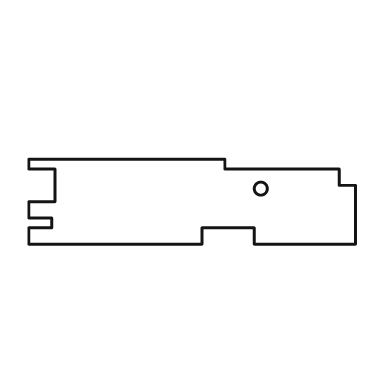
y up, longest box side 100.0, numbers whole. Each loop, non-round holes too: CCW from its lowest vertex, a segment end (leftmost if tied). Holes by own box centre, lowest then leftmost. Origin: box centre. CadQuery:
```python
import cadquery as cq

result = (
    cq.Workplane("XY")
    .moveTo(-50.0, -13.0)
    .lineTo(3.0, -13.0)
    .lineTo(3.0, -8.0)
    .lineTo(19.0, -8.0)
    .lineTo(19.0, -13.0)
    .lineTo(50.0, -13.0)
    .lineTo(50.0, 5.0)
    .lineTo(45.0, 5.0)
    .lineTo(45.0, 10.0)
    .lineTo(10.0, 10.0)
    .lineTo(10.0, 13.0)
    .lineTo(-50.0, 13.0)
    .lineTo(-50.0, 10.0)
    .lineTo(-42.0, 10.0)
    .lineTo(-42.0, 0.0)
    .lineTo(-50.0, 0.0)
    .lineTo(-50.0, -5.0)
    .lineTo(-43.0, -5.0)
    .lineTo(-43.0, -8.0)
    .lineTo(-50.0, -8.0)
    .close()
    .moveTo(21.0, 4.0)
    .circle(2.0)
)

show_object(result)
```